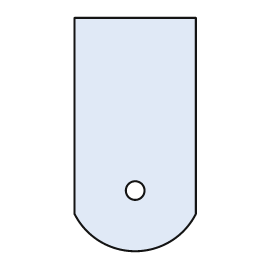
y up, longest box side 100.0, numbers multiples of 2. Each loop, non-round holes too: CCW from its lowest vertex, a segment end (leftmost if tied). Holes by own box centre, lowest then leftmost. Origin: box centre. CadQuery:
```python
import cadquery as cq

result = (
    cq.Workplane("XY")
    .moveTo(-26.0, -34.0)
    .threePointArc((0.0, -50.0), (26.0, -34.0))
    .lineTo(26.0, 50.0)
    .lineTo(-26.0, 50.0)
    .close()
    .moveTo(0.0, -24.0)
    .circle(4.0)
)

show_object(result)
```